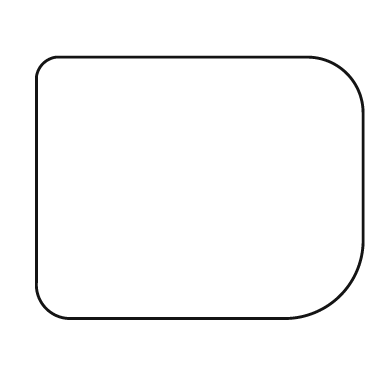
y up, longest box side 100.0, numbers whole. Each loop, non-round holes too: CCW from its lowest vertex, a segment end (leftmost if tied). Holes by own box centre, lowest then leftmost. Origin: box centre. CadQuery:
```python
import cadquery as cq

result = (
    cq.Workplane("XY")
    .moveTo(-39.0, -40.0)
    .lineTo(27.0, -40.0)
    .threePointArc((43.0, -33.0), (50.0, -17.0))
    .lineTo(50.0, 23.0)
    .threePointArc((45.0, 35.0), (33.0, 40.0))
    .lineTo(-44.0, 40.0)
    .threePointArc((-48.0, 38.0), (-50.0, 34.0))
    .lineTo(-50.0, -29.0)
    .threePointArc((-47.0, -37.0), (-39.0, -40.0))
    .close()
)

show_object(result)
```